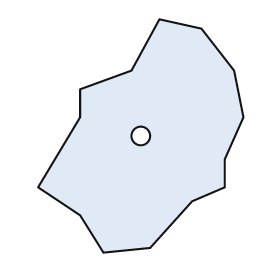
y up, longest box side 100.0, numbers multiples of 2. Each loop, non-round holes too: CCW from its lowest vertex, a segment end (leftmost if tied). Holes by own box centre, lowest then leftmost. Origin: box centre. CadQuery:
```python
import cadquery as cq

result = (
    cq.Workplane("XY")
    .moveTo(-16.0, -50.0)
    .lineTo(4.0, -48.0)
    .lineTo(22.0, -28.0)
    .lineTo(36.0, -22.0)
    .lineTo(36.0, -10.0)
    .lineTo(44.0, 8.0)
    .lineTo(40.0, 28.0)
    .lineTo(26.0, 46.0)
    .lineTo(8.0, 50.0)
    .lineTo(-4.0, 28.0)
    .lineTo(-26.0, 20.0)
    .lineTo(-26.0, 8.0)
    .lineTo(-44.0, -22.0)
    .lineTo(-26.0, -34.0)
    .close()
    .moveTo(0.0, 0.0)
    .circle(4.0)
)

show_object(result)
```